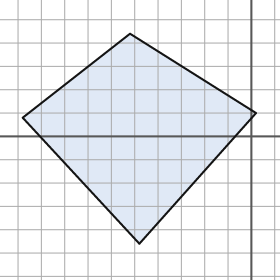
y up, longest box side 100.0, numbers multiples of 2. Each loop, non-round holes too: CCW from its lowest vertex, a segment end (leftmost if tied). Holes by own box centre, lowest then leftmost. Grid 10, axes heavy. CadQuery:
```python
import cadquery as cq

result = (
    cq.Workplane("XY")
    .moveTo(-48.0, -46.0)
    .lineTo(2.0, 10.0)
    .lineTo(-52.0, 44.0)
    .lineTo(-98.0, 8.0)
    .close()
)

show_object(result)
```